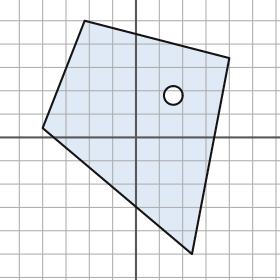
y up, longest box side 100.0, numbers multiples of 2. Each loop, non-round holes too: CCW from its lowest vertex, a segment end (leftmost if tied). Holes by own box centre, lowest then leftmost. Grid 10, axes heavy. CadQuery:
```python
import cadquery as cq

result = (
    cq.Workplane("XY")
    .moveTo(24.0, -50.0)
    .lineTo(40.0, 34.0)
    .lineTo(-22.0, 50.0)
    .lineTo(-40.0, 4.0)
    .close()
    .moveTo(16.0, 18.0)
    .circle(4.0)
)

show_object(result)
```